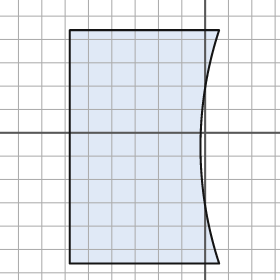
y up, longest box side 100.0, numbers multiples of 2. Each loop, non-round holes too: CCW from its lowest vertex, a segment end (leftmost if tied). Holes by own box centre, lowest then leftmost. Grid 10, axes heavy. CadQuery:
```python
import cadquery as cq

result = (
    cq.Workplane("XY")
    .moveTo(-58.0, -56.0)
    .lineTo(6.0, -56.0)
    .threePointArc((-2.0, -6.0), (6.0, 44.0))
    .lineTo(-58.0, 44.0)
    .close()
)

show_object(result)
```